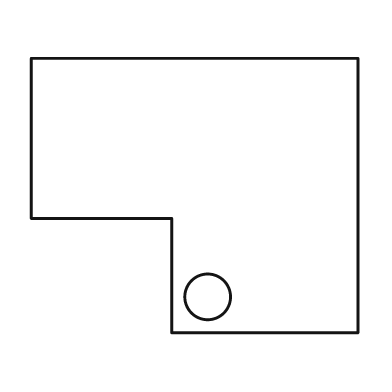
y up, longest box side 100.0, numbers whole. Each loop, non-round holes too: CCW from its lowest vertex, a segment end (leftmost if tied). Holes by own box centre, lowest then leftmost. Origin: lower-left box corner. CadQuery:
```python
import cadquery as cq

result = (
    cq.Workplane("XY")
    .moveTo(43.0, 0.0)
    .lineTo(100.0, 0.0)
    .lineTo(100.0, 84.0)
    .lineTo(0.0, 84.0)
    .lineTo(0.0, 35.0)
    .lineTo(43.0, 35.0)
    .close()
    .moveTo(54.0, 11.0)
    .circle(7.0)
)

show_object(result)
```